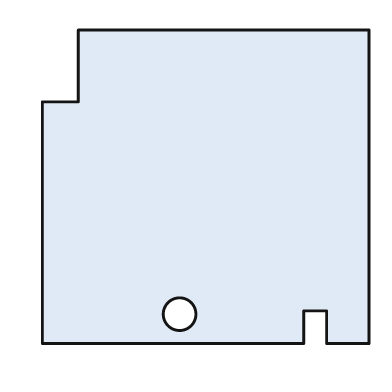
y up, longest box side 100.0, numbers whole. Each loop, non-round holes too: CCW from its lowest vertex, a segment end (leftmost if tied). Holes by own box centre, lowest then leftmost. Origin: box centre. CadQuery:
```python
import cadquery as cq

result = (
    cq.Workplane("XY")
    .moveTo(-50.0, -48.0)
    .lineTo(30.0, -48.0)
    .lineTo(30.0, -38.0)
    .lineTo(37.0, -38.0)
    .lineTo(37.0, -48.0)
    .lineTo(50.0, -48.0)
    .lineTo(50.0, 48.0)
    .lineTo(-39.0, 48.0)
    .lineTo(-39.0, 26.0)
    .lineTo(-50.0, 26.0)
    .close()
    .moveTo(-8.0, -39.0)
    .circle(5.0)
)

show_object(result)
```